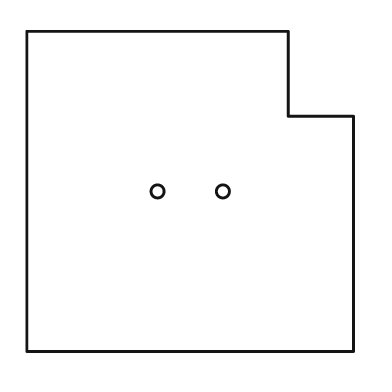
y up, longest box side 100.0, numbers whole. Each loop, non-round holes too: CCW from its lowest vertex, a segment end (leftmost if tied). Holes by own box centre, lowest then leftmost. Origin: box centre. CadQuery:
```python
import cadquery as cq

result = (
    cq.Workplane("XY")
    .moveTo(-50.0, -49.0)
    .lineTo(50.0, -49.0)
    .lineTo(50.0, 23.0)
    .lineTo(30.0, 23.0)
    .lineTo(30.0, 49.0)
    .lineTo(-50.0, 49.0)
    .close()
    .moveTo(-10.0, 0.0)
    .circle(2.0)
    .moveTo(10.0, 0.0)
    .circle(2.0)
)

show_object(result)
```